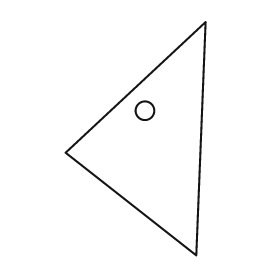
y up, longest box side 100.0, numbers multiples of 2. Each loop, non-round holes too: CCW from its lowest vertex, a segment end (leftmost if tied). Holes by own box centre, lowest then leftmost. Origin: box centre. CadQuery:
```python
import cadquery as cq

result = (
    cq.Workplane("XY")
    .moveTo(26.0, -50.0)
    .lineTo(30.0, 50.0)
    .lineTo(-30.0, -6.0)
    .close()
    .moveTo(4.0, 12.0)
    .circle(4.0)
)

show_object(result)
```